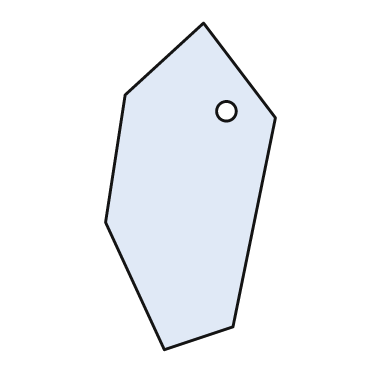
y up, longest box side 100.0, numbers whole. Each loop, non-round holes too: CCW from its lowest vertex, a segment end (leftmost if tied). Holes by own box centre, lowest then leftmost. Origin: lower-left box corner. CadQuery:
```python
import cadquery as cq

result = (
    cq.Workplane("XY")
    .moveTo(18.0, 0.0)
    .lineTo(39.0, 7.0)
    .lineTo(52.0, 71.0)
    .lineTo(30.0, 100.0)
    .lineTo(6.0, 78.0)
    .lineTo(0.0, 39.0)
    .close()
    .moveTo(37.0, 73.0)
    .circle(3.0)
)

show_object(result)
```